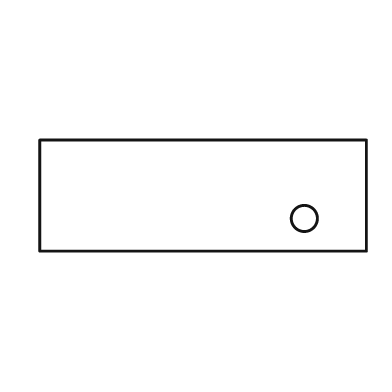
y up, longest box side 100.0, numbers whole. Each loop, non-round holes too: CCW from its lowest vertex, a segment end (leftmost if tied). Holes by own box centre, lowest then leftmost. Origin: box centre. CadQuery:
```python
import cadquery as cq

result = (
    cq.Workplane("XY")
    .moveTo(-50.0, -17.0)
    .lineTo(50.0, -17.0)
    .lineTo(50.0, 17.0)
    .lineTo(-50.0, 17.0)
    .close()
    .moveTo(31.0, -7.0)
    .circle(4.0)
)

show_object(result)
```